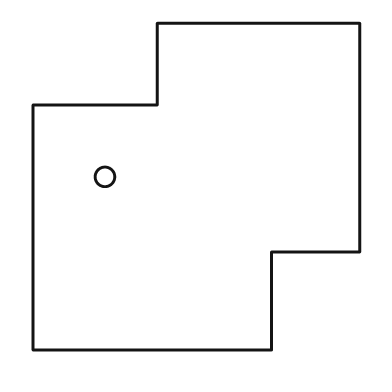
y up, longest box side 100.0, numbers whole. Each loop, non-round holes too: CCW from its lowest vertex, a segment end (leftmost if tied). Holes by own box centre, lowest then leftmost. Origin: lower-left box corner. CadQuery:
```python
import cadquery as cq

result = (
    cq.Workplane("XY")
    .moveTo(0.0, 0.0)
    .lineTo(73.0, 0.0)
    .lineTo(73.0, 30.0)
    .lineTo(100.0, 30.0)
    .lineTo(100.0, 100.0)
    .lineTo(38.0, 100.0)
    .lineTo(38.0, 75.0)
    .lineTo(0.0, 75.0)
    .close()
    .moveTo(22.0, 53.0)
    .circle(3.0)
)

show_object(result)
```